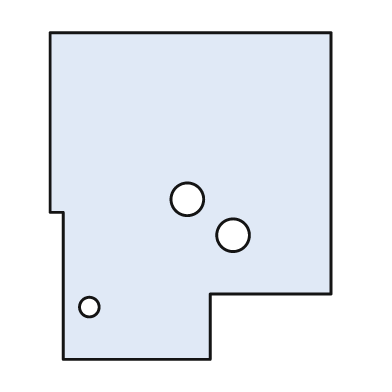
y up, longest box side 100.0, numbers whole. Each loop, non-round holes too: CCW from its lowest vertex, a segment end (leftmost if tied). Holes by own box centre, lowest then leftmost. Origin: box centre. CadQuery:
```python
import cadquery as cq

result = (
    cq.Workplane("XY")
    .moveTo(-39.0, -50.0)
    .lineTo(6.0, -50.0)
    .lineTo(6.0, -30.0)
    .lineTo(43.0, -30.0)
    .lineTo(43.0, 50.0)
    .lineTo(-43.0, 50.0)
    .lineTo(-43.0, -5.0)
    .lineTo(-39.0, -5.0)
    .close()
    .moveTo(-31.0, -34.0)
    .circle(3.0)
    .moveTo(13.0, -12.0)
    .circle(5.0)
    .moveTo(-1.0, -1.0)
    .circle(5.0)
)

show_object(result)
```